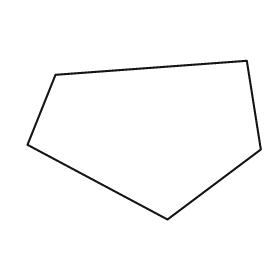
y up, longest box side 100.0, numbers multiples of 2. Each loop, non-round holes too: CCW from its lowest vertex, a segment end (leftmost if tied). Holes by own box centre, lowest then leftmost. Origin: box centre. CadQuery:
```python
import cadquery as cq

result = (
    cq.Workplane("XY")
    .moveTo(10.0, -34.0)
    .lineTo(50.0, -4.0)
    .lineTo(44.0, 34.0)
    .lineTo(-38.0, 28.0)
    .lineTo(-50.0, -2.0)
    .close()
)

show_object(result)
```